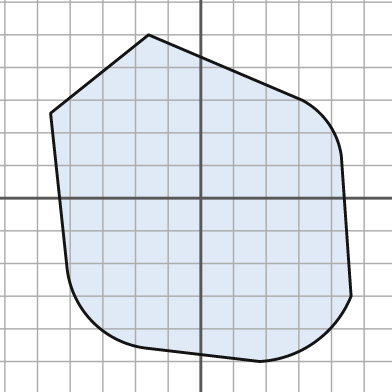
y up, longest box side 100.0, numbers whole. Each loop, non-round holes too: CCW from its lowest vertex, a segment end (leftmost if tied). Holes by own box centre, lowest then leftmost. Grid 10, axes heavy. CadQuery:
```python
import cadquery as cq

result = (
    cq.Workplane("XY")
    .moveTo(18.0, -50.0)
    .threePointArc((35.0, -44.0), (46.0, -30.0))
    .lineTo(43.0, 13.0)
    .threePointArc((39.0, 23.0), (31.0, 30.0))
    .lineTo(-16.0, 50.0)
    .lineTo(-46.0, 26.0)
    .lineTo(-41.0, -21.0)
    .threePointArc((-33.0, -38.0), (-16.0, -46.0))
    .close()
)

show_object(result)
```